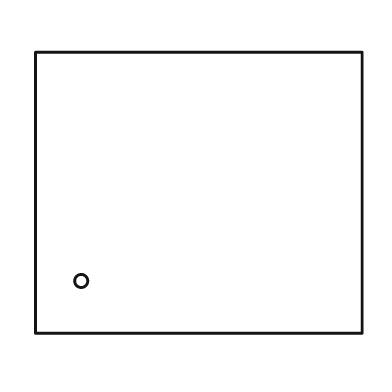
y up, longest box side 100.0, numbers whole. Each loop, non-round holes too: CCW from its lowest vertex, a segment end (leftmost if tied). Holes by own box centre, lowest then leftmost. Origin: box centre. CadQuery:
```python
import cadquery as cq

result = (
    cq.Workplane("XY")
    .moveTo(-50.0, -43.0)
    .lineTo(50.0, -43.0)
    .lineTo(50.0, 43.0)
    .lineTo(-50.0, 43.0)
    .close()
    .moveTo(-36.0, -27.0)
    .circle(2.0)
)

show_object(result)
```